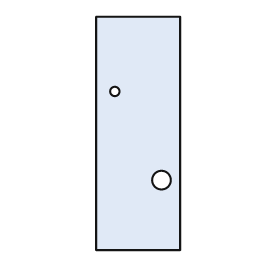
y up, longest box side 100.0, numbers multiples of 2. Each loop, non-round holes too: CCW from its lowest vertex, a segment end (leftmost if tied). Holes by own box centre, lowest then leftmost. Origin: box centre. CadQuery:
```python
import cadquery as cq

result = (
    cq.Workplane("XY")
    .moveTo(-18.0, -50.0)
    .lineTo(18.0, -50.0)
    .lineTo(18.0, 50.0)
    .lineTo(-18.0, 50.0)
    .close()
    .moveTo(10.0, -20.0)
    .circle(4.0)
    .moveTo(-10.0, 18.0)
    .circle(2.0)
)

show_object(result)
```